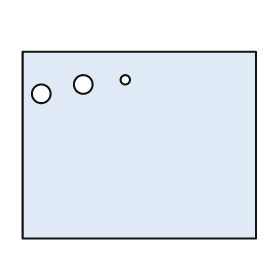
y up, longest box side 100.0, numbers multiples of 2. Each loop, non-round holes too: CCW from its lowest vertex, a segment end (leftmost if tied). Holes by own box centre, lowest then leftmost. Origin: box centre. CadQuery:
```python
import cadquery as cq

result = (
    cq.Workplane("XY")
    .moveTo(-50.0, -40.0)
    .lineTo(50.0, -40.0)
    .lineTo(50.0, 40.0)
    .lineTo(-50.0, 40.0)
    .close()
    .moveTo(-42.0, 22.0)
    .circle(4.0)
    .moveTo(-24.0, 26.0)
    .circle(4.0)
    .moveTo(-6.0, 28.0)
    .circle(2.0)
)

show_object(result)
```